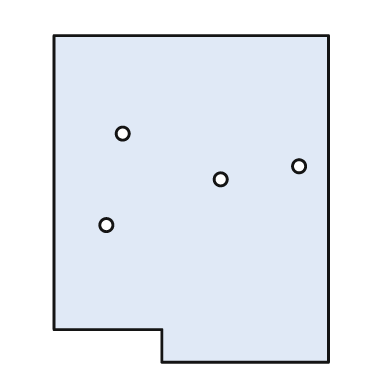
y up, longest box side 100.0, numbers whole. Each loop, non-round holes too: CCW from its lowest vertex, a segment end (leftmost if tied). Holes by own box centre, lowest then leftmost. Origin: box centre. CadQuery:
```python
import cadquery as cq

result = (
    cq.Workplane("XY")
    .moveTo(-9.0, -50.0)
    .lineTo(42.0, -50.0)
    .lineTo(42.0, 50.0)
    .lineTo(-42.0, 50.0)
    .lineTo(-42.0, -40.0)
    .lineTo(-9.0, -40.0)
    .close()
    .moveTo(-26.0, -8.0)
    .circle(2.0)
    .moveTo(9.0, 6.0)
    .circle(2.0)
    .moveTo(33.0, 10.0)
    .circle(2.0)
    .moveTo(-21.0, 20.0)
    .circle(2.0)
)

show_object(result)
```